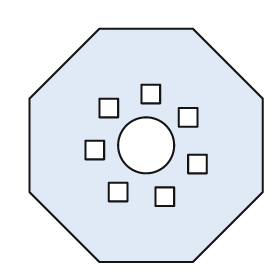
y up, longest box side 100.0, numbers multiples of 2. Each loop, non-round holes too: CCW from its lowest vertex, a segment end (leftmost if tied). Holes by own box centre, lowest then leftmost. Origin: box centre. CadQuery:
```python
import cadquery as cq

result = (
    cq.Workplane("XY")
    .moveTo(-20.0, -50.0)
    .lineTo(20.0, -50.0)
    .lineTo(50.0, -20.0)
    .lineTo(50.0, 20.0)
    .lineTo(20.0, 50.0)
    .lineTo(-20.0, 50.0)
    .lineTo(-50.0, 20.0)
    .lineTo(-50.0, -20.0)
    .close()
    .moveTo(4.0, -26.0)
    .lineTo(12.0, -26.0)
    .lineTo(12.0, -18.0)
    .lineTo(4.0, -18.0)
    .close()
    .moveTo(-16.0, -24.0)
    .lineTo(-8.0, -24.0)
    .lineTo(-8.0, -16.0)
    .lineTo(-16.0, -16.0)
    .close()
    .moveTo(18.0, -12.0)
    .lineTo(26.0, -12.0)
    .lineTo(26.0, -4.0)
    .lineTo(18.0, -4.0)
    .close()
    .moveTo(-26.0, -6.0)
    .lineTo(-18.0, -6.0)
    .lineTo(-18.0, 2.0)
    .lineTo(-26.0, 2.0)
    .close()
    .moveTo(0.0, 0.0)
    .circle(12.0)
    .moveTo(14.0, 8.0)
    .lineTo(22.0, 8.0)
    .lineTo(22.0, 16.0)
    .lineTo(14.0, 16.0)
    .close()
    .moveTo(-20.0, 12.0)
    .lineTo(-12.0, 12.0)
    .lineTo(-12.0, 20.0)
    .lineTo(-20.0, 20.0)
    .close()
    .moveTo(-2.0, 18.0)
    .lineTo(6.0, 18.0)
    .lineTo(6.0, 26.0)
    .lineTo(-2.0, 26.0)
    .close()
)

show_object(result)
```